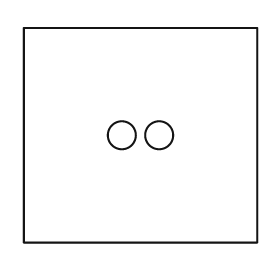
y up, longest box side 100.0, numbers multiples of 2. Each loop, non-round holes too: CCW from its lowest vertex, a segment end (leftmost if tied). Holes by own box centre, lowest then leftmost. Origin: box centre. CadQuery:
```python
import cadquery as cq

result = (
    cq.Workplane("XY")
    .moveTo(-50.0, -46.0)
    .lineTo(50.0, -46.0)
    .lineTo(50.0, 46.0)
    .lineTo(-50.0, 46.0)
    .close()
    .moveTo(-8.0, 0.0)
    .circle(6.0)
    .moveTo(8.0, 0.0)
    .circle(6.0)
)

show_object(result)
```